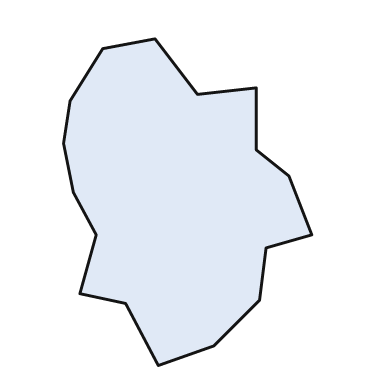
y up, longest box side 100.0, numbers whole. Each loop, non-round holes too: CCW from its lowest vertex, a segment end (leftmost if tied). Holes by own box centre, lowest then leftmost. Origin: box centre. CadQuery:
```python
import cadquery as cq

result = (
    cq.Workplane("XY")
    .moveTo(-9.0, -50.0)
    .lineTo(8.0, -44.0)
    .lineTo(22.0, -30.0)
    .lineTo(24.0, -14.0)
    .lineTo(38.0, -10.0)
    .lineTo(31.0, 8.0)
    .lineTo(21.0, 16.0)
    .lineTo(21.0, 35.0)
    .lineTo(3.0, 33.0)
    .lineTo(-10.0, 50.0)
    .lineTo(-26.0, 47.0)
    .lineTo(-36.0, 31.0)
    .lineTo(-38.0, 18.0)
    .lineTo(-35.0, 3.0)
    .lineTo(-28.0, -10.0)
    .lineTo(-33.0, -28.0)
    .lineTo(-19.0, -31.0)
    .close()
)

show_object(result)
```